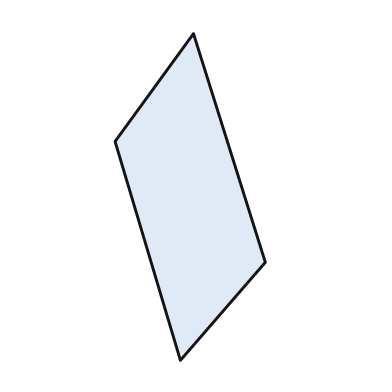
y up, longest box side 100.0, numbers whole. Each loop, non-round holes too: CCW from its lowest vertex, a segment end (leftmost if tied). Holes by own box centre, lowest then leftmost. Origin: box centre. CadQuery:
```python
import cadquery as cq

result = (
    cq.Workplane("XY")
    .moveTo(-3.0, -50.0)
    .lineTo(23.0, -20.0)
    .lineTo(1.0, 50.0)
    .lineTo(-23.0, 17.0)
    .close()
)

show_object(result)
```